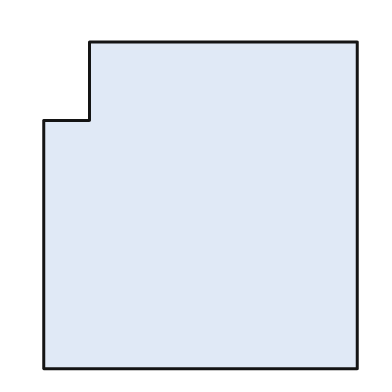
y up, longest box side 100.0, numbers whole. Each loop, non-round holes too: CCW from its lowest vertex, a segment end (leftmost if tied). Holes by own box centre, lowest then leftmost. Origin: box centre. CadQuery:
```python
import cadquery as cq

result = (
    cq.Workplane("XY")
    .moveTo(-48.0, -50.0)
    .lineTo(48.0, -50.0)
    .lineTo(48.0, 50.0)
    .lineTo(-34.0, 50.0)
    .lineTo(-34.0, 26.0)
    .lineTo(-48.0, 26.0)
    .close()
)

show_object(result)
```